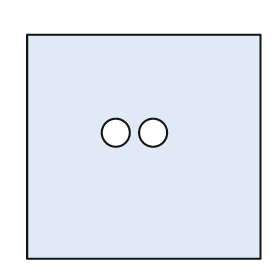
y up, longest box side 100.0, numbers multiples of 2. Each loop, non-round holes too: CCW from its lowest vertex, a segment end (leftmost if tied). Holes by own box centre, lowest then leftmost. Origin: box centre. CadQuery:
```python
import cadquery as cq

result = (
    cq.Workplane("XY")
    .moveTo(-50.0, -48.0)
    .lineTo(50.0, -48.0)
    .lineTo(50.0, 48.0)
    .lineTo(-50.0, 48.0)
    .close()
    .moveTo(-12.0, 6.0)
    .circle(6.0)
    .moveTo(4.0, 6.0)
    .circle(6.0)
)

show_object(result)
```